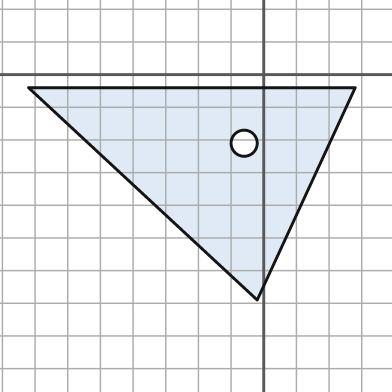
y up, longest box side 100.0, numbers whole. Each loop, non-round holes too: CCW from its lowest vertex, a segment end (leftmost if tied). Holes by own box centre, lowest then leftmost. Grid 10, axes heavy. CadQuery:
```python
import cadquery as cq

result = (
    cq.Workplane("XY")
    .moveTo(-2.0, -69.0)
    .lineTo(28.0, -4.0)
    .lineTo(-72.0, -4.0)
    .close()
    .moveTo(-6.0, -21.0)
    .circle(4.0)
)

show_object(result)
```